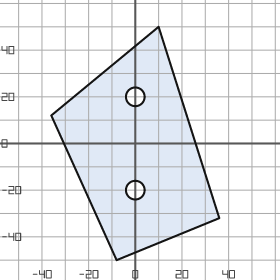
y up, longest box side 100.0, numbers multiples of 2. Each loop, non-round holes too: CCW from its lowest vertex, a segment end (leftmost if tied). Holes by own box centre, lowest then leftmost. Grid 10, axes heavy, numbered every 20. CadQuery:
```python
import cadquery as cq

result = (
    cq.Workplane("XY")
    .moveTo(-8.0, -50.0)
    .lineTo(36.0, -32.0)
    .lineTo(10.0, 50.0)
    .lineTo(-36.0, 12.0)
    .close()
    .moveTo(0.0, -20.0)
    .circle(4.0)
    .moveTo(0.0, 20.0)
    .circle(4.0)
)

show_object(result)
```